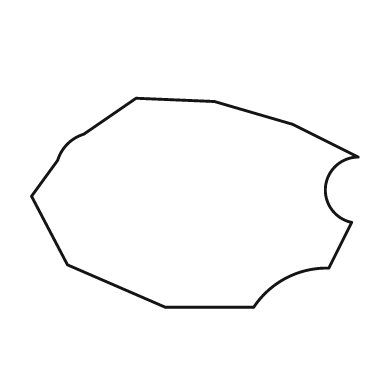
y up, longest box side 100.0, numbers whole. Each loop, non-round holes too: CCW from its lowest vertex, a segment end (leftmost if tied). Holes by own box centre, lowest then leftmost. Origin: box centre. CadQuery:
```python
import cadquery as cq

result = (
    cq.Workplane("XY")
    .moveTo(-9.0, -32.0)
    .lineTo(18.0, -32.0)
    .threePointArc((28.0, -23.0), (41.0, -20.0))
    .lineTo(48.0, -6.0)
    .threePointArc((40.0, 5.0), (50.0, 14.0))
    .lineTo(30.0, 24.0)
    .lineTo(6.0, 31.0)
    .lineTo(-18.0, 32.0)
    .lineTo(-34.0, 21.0)
    .threePointArc((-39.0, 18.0), (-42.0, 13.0))
    .lineTo(-50.0, 2.0)
    .lineTo(-39.0, -19.0)
    .close()
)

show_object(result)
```